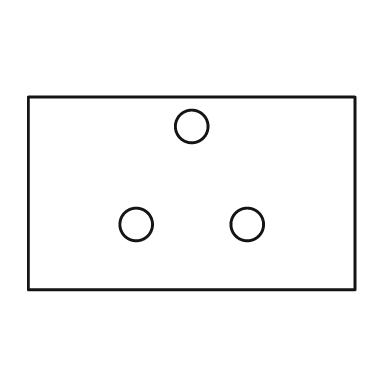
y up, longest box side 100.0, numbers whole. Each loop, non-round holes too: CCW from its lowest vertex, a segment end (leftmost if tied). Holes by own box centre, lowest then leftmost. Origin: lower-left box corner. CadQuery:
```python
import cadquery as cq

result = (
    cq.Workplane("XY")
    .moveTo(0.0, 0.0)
    .lineTo(100.0, 0.0)
    .lineTo(100.0, 59.0)
    .lineTo(0.0, 59.0)
    .close()
    .moveTo(33.0, 20.0)
    .circle(5.0)
    .moveTo(67.0, 20.0)
    .circle(5.0)
    .moveTo(50.0, 50.0)
    .circle(5.0)
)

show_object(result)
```